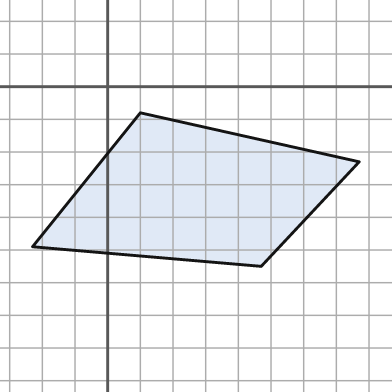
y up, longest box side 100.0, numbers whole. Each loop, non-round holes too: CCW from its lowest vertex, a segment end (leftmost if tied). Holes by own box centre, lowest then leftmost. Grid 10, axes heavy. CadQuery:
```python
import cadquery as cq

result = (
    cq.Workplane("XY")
    .moveTo(47.0, -55.0)
    .lineTo(77.0, -23.0)
    .lineTo(10.0, -8.0)
    .lineTo(-23.0, -49.0)
    .close()
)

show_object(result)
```